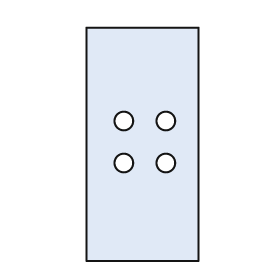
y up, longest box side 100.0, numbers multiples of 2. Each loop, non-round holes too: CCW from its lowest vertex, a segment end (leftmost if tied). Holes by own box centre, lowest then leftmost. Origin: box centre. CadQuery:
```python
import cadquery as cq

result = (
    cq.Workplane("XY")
    .moveTo(-24.0, -50.0)
    .lineTo(24.0, -50.0)
    .lineTo(24.0, 50.0)
    .lineTo(-24.0, 50.0)
    .close()
    .moveTo(-8.0, -8.0)
    .circle(4.0)
    .moveTo(10.0, -8.0)
    .circle(4.0)
    .moveTo(-8.0, 10.0)
    .circle(4.0)
    .moveTo(10.0, 10.0)
    .circle(4.0)
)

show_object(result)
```